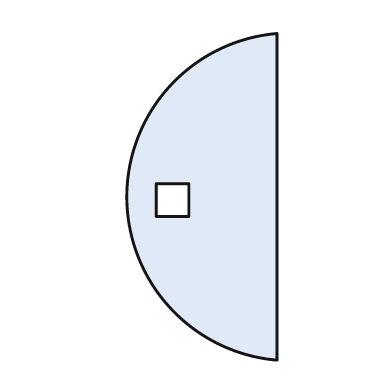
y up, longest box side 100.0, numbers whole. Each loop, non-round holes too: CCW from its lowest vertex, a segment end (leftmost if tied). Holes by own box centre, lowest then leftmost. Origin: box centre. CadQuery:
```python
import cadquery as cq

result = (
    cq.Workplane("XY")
    .moveTo(23.0, -50.0)
    .lineTo(23.0, 50.0)
    .threePointArc((-23.0, 0.0), (23.0, -50.0))
    .close()
    .moveTo(-14.0, -6.0)
    .lineTo(-4.0, -6.0)
    .lineTo(-4.0, 4.0)
    .lineTo(-14.0, 4.0)
    .close()
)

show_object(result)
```